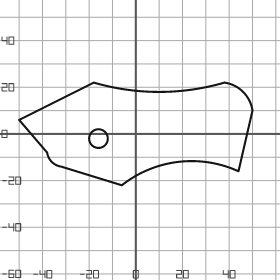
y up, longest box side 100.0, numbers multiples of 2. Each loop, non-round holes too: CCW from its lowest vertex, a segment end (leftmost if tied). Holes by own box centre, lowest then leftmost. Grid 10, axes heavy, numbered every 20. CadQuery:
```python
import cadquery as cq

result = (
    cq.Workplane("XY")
    .moveTo(-6.0, -22.0)
    .threePointArc((18.0, -12.0), (44.0, -16.0))
    .lineTo(50.0, 10.0)
    .threePointArc((46.0, 18.0), (38.0, 22.0))
    .threePointArc((10.0, 18.0), (-18.0, 22.0))
    .lineTo(-50.0, 6.0)
    .lineTo(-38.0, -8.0)
    .threePointArc((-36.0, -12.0), (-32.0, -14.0))
    .close()
    .moveTo(-16.0, -2.0)
    .circle(4.0)
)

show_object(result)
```